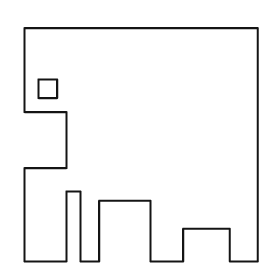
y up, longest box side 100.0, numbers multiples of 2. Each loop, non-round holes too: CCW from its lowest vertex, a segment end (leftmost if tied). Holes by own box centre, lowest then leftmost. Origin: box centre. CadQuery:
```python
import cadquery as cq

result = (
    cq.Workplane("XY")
    .moveTo(-50.0, -50.0)
    .lineTo(-32.0, -50.0)
    .lineTo(-32.0, -20.0)
    .lineTo(-26.0, -20.0)
    .lineTo(-26.0, -50.0)
    .lineTo(-18.0, -50.0)
    .lineTo(-18.0, -24.0)
    .lineTo(4.0, -24.0)
    .lineTo(4.0, -50.0)
    .lineTo(18.0, -50.0)
    .lineTo(18.0, -36.0)
    .lineTo(38.0, -36.0)
    .lineTo(38.0, -50.0)
    .lineTo(50.0, -50.0)
    .lineTo(50.0, 50.0)
    .lineTo(-50.0, 50.0)
    .lineTo(-50.0, 14.0)
    .lineTo(-32.0, 14.0)
    .lineTo(-32.0, -10.0)
    .lineTo(-50.0, -10.0)
    .close()
    .moveTo(-44.0, 20.0)
    .lineTo(-36.0, 20.0)
    .lineTo(-36.0, 28.0)
    .lineTo(-44.0, 28.0)
    .close()
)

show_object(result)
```